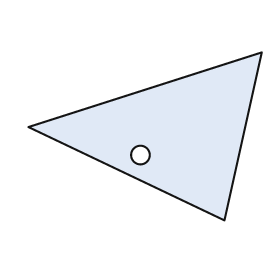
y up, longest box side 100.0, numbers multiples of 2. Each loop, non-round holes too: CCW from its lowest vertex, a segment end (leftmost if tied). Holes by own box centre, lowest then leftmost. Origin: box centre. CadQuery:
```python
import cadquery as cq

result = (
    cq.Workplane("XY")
    .moveTo(34.0, -36.0)
    .lineTo(50.0, 36.0)
    .lineTo(-50.0, 4.0)
    .close()
    .moveTo(-2.0, -8.0)
    .circle(4.0)
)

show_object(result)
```